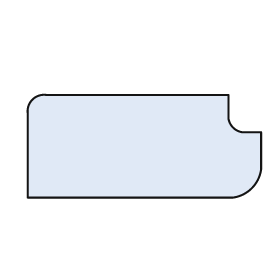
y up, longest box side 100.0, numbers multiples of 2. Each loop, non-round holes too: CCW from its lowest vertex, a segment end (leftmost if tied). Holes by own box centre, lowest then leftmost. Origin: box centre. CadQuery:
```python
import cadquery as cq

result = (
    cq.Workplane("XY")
    .moveTo(-50.0, -22.0)
    .lineTo(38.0, -22.0)
    .threePointArc((46.0, -18.0), (50.0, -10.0))
    .lineTo(50.0, 6.0)
    .lineTo(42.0, 6.0)
    .threePointArc((38.0, 8.0), (36.0, 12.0))
    .lineTo(36.0, 22.0)
    .lineTo(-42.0, 22.0)
    .threePointArc((-48.0, 20.0), (-50.0, 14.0))
    .close()
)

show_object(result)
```